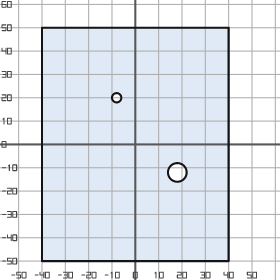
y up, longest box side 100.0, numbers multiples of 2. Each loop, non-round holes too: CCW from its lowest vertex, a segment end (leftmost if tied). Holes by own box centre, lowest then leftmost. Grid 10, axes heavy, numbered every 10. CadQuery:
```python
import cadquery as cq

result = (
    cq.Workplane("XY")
    .moveTo(-40.0, -50.0)
    .lineTo(40.0, -50.0)
    .lineTo(40.0, 50.0)
    .lineTo(-40.0, 50.0)
    .close()
    .moveTo(18.0, -12.0)
    .circle(4.0)
    .moveTo(-8.0, 20.0)
    .circle(2.0)
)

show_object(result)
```